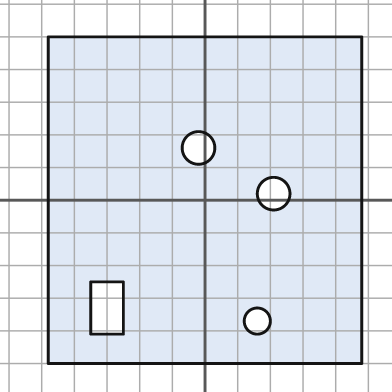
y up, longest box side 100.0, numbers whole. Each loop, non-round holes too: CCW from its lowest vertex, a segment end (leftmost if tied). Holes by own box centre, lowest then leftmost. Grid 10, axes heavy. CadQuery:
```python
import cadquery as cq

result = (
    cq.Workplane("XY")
    .moveTo(-48.0, -50.0)
    .lineTo(48.0, -50.0)
    .lineTo(48.0, 50.0)
    .lineTo(-48.0, 50.0)
    .close()
    .moveTo(16.0, -37.0)
    .circle(4.0)
    .moveTo(-35.0, -41.0)
    .lineTo(-25.0, -41.0)
    .lineTo(-25.0, -25.0)
    .lineTo(-35.0, -25.0)
    .close()
    .moveTo(21.0, 2.0)
    .circle(5.0)
    .moveTo(-2.0, 16.0)
    .circle(5.0)
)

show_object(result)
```